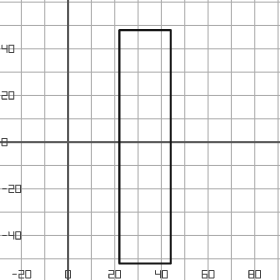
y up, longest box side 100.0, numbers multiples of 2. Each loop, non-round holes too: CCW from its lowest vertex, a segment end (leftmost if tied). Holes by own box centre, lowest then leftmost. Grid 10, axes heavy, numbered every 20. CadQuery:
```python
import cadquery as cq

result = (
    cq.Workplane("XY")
    .moveTo(22.0, -52.0)
    .lineTo(44.0, -52.0)
    .lineTo(44.0, 48.0)
    .lineTo(22.0, 48.0)
    .close()
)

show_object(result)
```